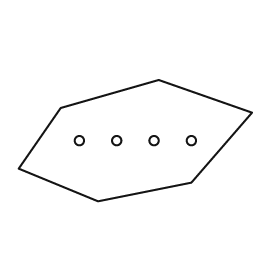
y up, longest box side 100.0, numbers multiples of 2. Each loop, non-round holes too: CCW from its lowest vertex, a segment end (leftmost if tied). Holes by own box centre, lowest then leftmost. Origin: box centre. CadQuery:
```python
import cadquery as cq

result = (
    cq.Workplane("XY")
    .moveTo(-16.0, -26.0)
    .lineTo(24.0, -18.0)
    .lineTo(50.0, 12.0)
    .lineTo(10.0, 26.0)
    .lineTo(-32.0, 14.0)
    .lineTo(-50.0, -12.0)
    .close()
    .moveTo(-24.0, 0.0)
    .circle(2.0)
    .moveTo(-8.0, 0.0)
    .circle(2.0)
    .moveTo(8.0, 0.0)
    .circle(2.0)
    .moveTo(24.0, 0.0)
    .circle(2.0)
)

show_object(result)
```